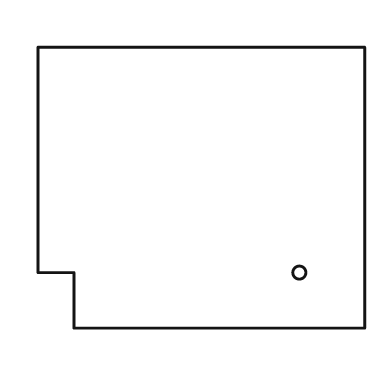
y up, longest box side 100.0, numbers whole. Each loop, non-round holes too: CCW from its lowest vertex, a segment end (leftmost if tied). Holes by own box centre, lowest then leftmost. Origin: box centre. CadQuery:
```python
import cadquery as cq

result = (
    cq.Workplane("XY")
    .moveTo(-39.0, -43.0)
    .lineTo(50.0, -43.0)
    .lineTo(50.0, 43.0)
    .lineTo(-50.0, 43.0)
    .lineTo(-50.0, -26.0)
    .lineTo(-39.0, -26.0)
    .close()
    .moveTo(30.0, -26.0)
    .circle(2.0)
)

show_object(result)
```